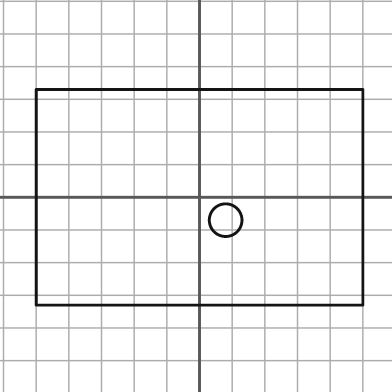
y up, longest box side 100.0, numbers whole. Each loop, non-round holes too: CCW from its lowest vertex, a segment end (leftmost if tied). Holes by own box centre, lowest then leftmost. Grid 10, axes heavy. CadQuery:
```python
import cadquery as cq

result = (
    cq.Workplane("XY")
    .moveTo(-50.0, -33.0)
    .lineTo(50.0, -33.0)
    .lineTo(50.0, 33.0)
    .lineTo(-50.0, 33.0)
    .close()
    .moveTo(8.0, -7.0)
    .circle(5.0)
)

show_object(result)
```